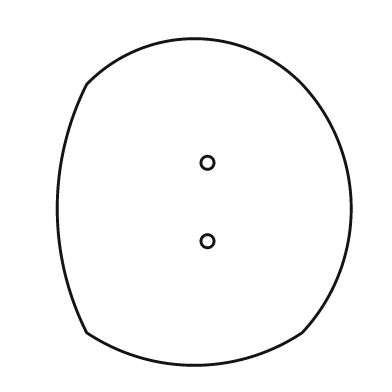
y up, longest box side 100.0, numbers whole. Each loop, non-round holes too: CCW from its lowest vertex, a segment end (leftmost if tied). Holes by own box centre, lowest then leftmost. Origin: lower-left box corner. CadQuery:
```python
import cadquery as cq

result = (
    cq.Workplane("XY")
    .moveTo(9.0, 10.0)
    .threePointArc((42.0, 0.0), (75.0, 10.0))
    .threePointArc((90.0, 48.0), (75.0, 86.0))
    .threePointArc((42.0, 100.0), (9.0, 86.0))
    .threePointArc((0.0, 48.0), (9.0, 10.0))
    .close()
    .moveTo(46.0, 38.0)
    .circle(2.0)
    .moveTo(46.0, 62.0)
    .circle(2.0)
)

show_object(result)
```